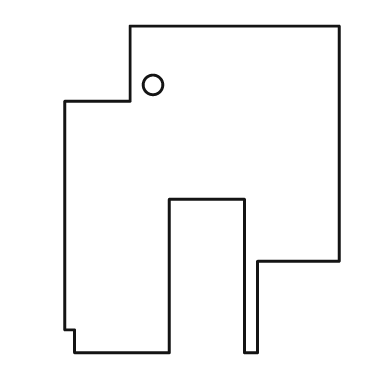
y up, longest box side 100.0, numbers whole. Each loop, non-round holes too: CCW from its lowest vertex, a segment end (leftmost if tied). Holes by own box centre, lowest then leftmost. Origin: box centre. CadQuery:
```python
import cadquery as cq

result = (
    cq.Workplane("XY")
    .moveTo(-39.0, -50.0)
    .lineTo(-10.0, -50.0)
    .lineTo(-10.0, -3.0)
    .lineTo(13.0, -3.0)
    .lineTo(13.0, -50.0)
    .lineTo(17.0, -50.0)
    .lineTo(17.0, -22.0)
    .lineTo(42.0, -22.0)
    .lineTo(42.0, 50.0)
    .lineTo(-22.0, 50.0)
    .lineTo(-22.0, 27.0)
    .lineTo(-42.0, 27.0)
    .lineTo(-42.0, -43.0)
    .lineTo(-39.0, -43.0)
    .close()
    .moveTo(-15.0, 32.0)
    .circle(3.0)
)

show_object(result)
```